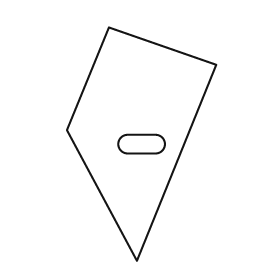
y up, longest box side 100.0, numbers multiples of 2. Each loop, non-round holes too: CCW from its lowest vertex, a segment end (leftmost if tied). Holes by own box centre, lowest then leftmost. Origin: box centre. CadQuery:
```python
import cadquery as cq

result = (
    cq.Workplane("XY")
    .moveTo(-2.0, -50.0)
    .lineTo(32.0, 34.0)
    .lineTo(-14.0, 50.0)
    .lineTo(-32.0, 6.0)
    .close()
    .moveTo(-6.0, -4.0)
    .lineTo(6.0, -4.0)
    .threePointArc((10.0, 0.0), (6.0, 4.0))
    .lineTo(-6.0, 4.0)
    .threePointArc((-10.0, 0.0), (-6.0, -4.0))
    .close()
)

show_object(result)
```